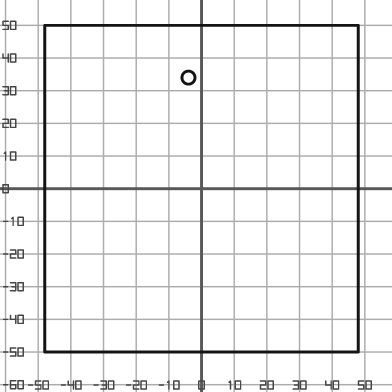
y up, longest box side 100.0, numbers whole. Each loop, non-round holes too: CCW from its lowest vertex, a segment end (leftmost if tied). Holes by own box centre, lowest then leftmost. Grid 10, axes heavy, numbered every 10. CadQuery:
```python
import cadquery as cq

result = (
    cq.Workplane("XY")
    .moveTo(-48.0, -50.0)
    .lineTo(48.0, -50.0)
    .lineTo(48.0, 50.0)
    .lineTo(-48.0, 50.0)
    .close()
    .moveTo(-4.0, 34.0)
    .circle(2.0)
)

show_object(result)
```